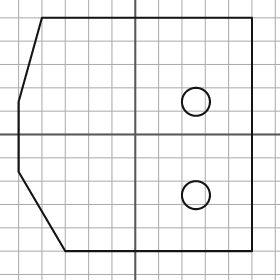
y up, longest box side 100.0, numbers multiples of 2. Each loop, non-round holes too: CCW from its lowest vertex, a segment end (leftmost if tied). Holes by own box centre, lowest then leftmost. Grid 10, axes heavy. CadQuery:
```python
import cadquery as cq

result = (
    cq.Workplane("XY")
    .moveTo(-30.0, -50.0)
    .lineTo(50.0, -50.0)
    .lineTo(50.0, 50.0)
    .lineTo(-40.0, 50.0)
    .lineTo(-50.0, 14.0)
    .lineTo(-50.0, -16.0)
    .close()
    .moveTo(26.0, -26.0)
    .circle(6.0)
    .moveTo(26.0, 14.0)
    .circle(6.0)
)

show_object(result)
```